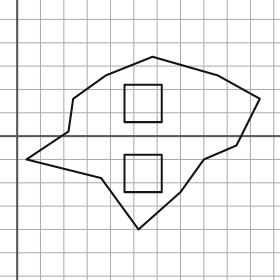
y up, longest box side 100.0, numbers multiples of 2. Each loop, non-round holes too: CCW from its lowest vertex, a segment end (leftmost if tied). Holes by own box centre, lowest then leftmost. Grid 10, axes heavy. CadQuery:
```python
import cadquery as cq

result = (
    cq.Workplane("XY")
    .moveTo(52.0, -40.0)
    .lineTo(70.0, -24.0)
    .lineTo(80.0, -10.0)
    .lineTo(94.0, -4.0)
    .lineTo(104.0, 16.0)
    .lineTo(86.0, 26.0)
    .lineTo(58.0, 34.0)
    .lineTo(38.0, 26.0)
    .lineTo(24.0, 16.0)
    .lineTo(22.0, 2.0)
    .lineTo(4.0, -10.0)
    .lineTo(36.0, -18.0)
    .close()
    .moveTo(46.0, -24.0)
    .lineTo(62.0, -24.0)
    .lineTo(62.0, -8.0)
    .lineTo(46.0, -8.0)
    .close()
    .moveTo(46.0, 6.0)
    .lineTo(62.0, 6.0)
    .lineTo(62.0, 22.0)
    .lineTo(46.0, 22.0)
    .close()
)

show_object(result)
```